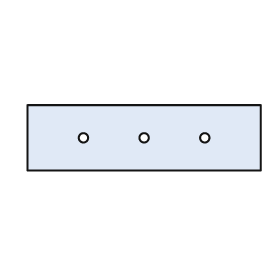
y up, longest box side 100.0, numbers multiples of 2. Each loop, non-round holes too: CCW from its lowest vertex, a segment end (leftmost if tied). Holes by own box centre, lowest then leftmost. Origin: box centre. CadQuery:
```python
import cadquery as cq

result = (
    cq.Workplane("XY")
    .moveTo(-50.0, -14.0)
    .lineTo(50.0, -14.0)
    .lineTo(50.0, 14.0)
    .lineTo(-50.0, 14.0)
    .close()
    .moveTo(-26.0, 0.0)
    .circle(2.0)
    .moveTo(0.0, 0.0)
    .circle(2.0)
    .moveTo(26.0, 0.0)
    .circle(2.0)
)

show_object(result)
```